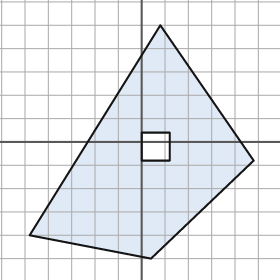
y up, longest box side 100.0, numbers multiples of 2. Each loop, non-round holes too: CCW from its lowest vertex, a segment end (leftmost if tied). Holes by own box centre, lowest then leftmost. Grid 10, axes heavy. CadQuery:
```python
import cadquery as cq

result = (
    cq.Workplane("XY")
    .moveTo(4.0, -50.0)
    .lineTo(48.0, -8.0)
    .lineTo(8.0, 50.0)
    .lineTo(-48.0, -40.0)
    .close()
    .moveTo(0.0, -8.0)
    .lineTo(12.0, -8.0)
    .lineTo(12.0, 4.0)
    .lineTo(0.0, 4.0)
    .close()
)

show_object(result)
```